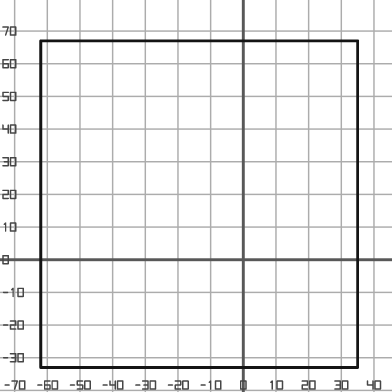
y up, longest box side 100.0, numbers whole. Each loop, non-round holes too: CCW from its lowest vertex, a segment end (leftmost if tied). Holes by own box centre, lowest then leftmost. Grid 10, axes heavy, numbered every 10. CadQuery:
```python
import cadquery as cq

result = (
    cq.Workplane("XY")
    .moveTo(-62.0, -33.0)
    .lineTo(35.0, -33.0)
    .lineTo(35.0, 67.0)
    .lineTo(-62.0, 67.0)
    .close()
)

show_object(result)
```